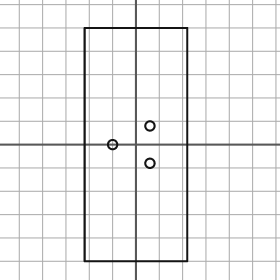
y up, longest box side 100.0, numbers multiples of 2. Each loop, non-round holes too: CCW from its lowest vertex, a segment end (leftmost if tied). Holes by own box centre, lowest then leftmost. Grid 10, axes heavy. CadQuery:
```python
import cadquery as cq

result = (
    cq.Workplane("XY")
    .moveTo(-22.0, -50.0)
    .lineTo(22.0, -50.0)
    .lineTo(22.0, 50.0)
    .lineTo(-22.0, 50.0)
    .close()
    .moveTo(6.0, -8.0)
    .circle(2.0)
    .moveTo(-10.0, 0.0)
    .circle(2.0)
    .moveTo(6.0, 8.0)
    .circle(2.0)
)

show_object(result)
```